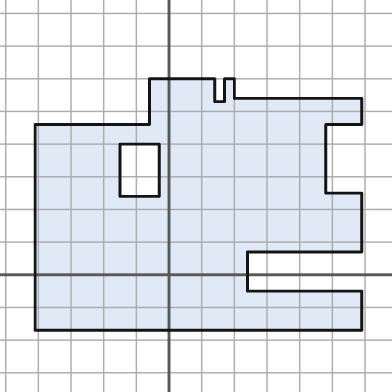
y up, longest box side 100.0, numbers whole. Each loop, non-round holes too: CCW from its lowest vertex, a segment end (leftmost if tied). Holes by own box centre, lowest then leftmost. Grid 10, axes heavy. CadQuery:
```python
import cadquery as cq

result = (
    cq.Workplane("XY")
    .moveTo(-41.0, -17.0)
    .lineTo(59.0, -17.0)
    .lineTo(59.0, -5.0)
    .lineTo(24.0, -5.0)
    .lineTo(24.0, 7.0)
    .lineTo(59.0, 7.0)
    .lineTo(59.0, 25.0)
    .lineTo(48.0, 25.0)
    .lineTo(48.0, 46.0)
    .lineTo(59.0, 46.0)
    .lineTo(59.0, 54.0)
    .lineTo(20.0, 54.0)
    .lineTo(20.0, 60.0)
    .lineTo(17.0, 60.0)
    .lineTo(17.0, 53.0)
    .lineTo(14.0, 53.0)
    .lineTo(14.0, 60.0)
    .lineTo(-6.0, 60.0)
    .lineTo(-6.0, 46.0)
    .lineTo(-41.0, 46.0)
    .close()
    .moveTo(-15.0, 24.0)
    .lineTo(-3.0, 24.0)
    .lineTo(-3.0, 40.0)
    .lineTo(-15.0, 40.0)
    .close()
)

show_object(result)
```